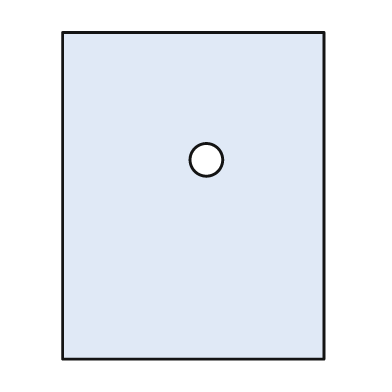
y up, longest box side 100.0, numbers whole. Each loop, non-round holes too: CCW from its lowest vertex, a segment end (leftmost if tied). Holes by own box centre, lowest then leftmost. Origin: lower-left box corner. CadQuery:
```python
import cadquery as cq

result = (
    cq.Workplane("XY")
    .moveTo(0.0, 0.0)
    .lineTo(80.0, 0.0)
    .lineTo(80.0, 100.0)
    .lineTo(0.0, 100.0)
    .close()
    .moveTo(44.0, 61.0)
    .circle(5.0)
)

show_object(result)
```